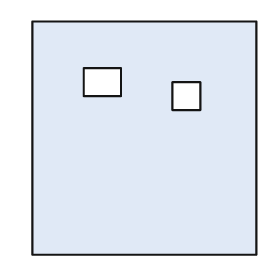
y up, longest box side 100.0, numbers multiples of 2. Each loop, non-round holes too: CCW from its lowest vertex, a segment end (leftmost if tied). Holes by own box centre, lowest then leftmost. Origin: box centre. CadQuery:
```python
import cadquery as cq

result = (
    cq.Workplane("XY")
    .moveTo(-48.0, -50.0)
    .lineTo(48.0, -50.0)
    .lineTo(48.0, 50.0)
    .lineTo(-48.0, 50.0)
    .close()
    .moveTo(12.0, 12.0)
    .lineTo(24.0, 12.0)
    .lineTo(24.0, 24.0)
    .lineTo(12.0, 24.0)
    .close()
    .moveTo(-26.0, 18.0)
    .lineTo(-10.0, 18.0)
    .lineTo(-10.0, 30.0)
    .lineTo(-26.0, 30.0)
    .close()
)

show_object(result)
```